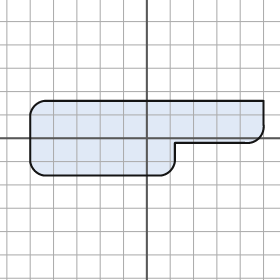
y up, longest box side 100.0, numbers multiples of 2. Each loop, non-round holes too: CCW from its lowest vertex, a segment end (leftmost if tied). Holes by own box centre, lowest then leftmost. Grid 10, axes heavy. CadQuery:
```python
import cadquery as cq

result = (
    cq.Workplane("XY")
    .moveTo(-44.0, -16.0)
    .lineTo(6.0, -16.0)
    .threePointArc((10.0, -14.0), (12.0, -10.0))
    .lineTo(12.0, -2.0)
    .lineTo(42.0, -2.0)
    .threePointArc((48.0, 0.0), (50.0, 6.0))
    .lineTo(50.0, 16.0)
    .lineTo(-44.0, 16.0)
    .threePointArc((-48.0, 14.0), (-50.0, 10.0))
    .lineTo(-50.0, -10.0)
    .threePointArc((-48.0, -14.0), (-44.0, -16.0))
    .close()
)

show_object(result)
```